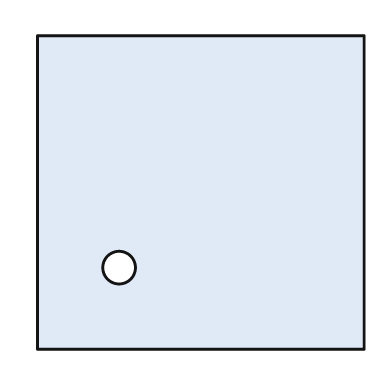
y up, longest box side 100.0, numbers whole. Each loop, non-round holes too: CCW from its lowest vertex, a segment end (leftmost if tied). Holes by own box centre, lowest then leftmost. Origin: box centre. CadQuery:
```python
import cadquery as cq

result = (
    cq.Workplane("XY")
    .moveTo(-50.0, -48.0)
    .lineTo(50.0, -48.0)
    .lineTo(50.0, 48.0)
    .lineTo(-50.0, 48.0)
    .close()
    .moveTo(-25.0, -23.0)
    .circle(5.0)
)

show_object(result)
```